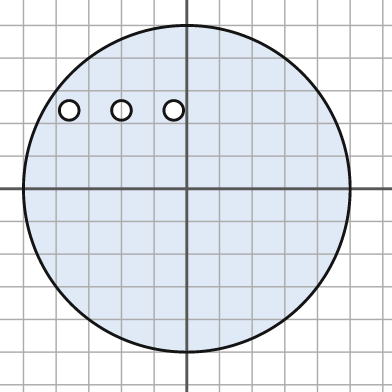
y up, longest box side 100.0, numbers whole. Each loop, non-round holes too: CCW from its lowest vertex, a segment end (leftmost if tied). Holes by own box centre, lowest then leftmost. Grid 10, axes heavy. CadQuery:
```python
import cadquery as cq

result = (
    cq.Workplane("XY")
    .moveTo(0.0, 0.0)
    .circle(50.0)
    .moveTo(-36.0, 24.0)
    .circle(3.0)
    .moveTo(-20.0, 24.0)
    .circle(3.0)
    .moveTo(-4.0, 24.0)
    .circle(3.0)
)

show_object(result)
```